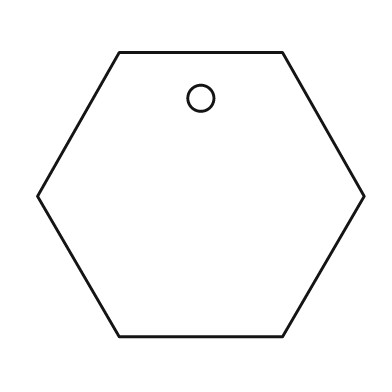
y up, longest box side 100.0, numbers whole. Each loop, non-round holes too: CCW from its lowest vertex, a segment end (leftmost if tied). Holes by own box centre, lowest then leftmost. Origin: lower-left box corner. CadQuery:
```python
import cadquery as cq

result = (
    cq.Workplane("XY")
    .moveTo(25.0, 0.0)
    .lineTo(75.0, 0.0)
    .lineTo(100.0, 43.0)
    .lineTo(75.0, 87.0)
    .lineTo(25.0, 87.0)
    .lineTo(0.0, 43.0)
    .close()
    .moveTo(50.0, 73.0)
    .circle(4.0)
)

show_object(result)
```